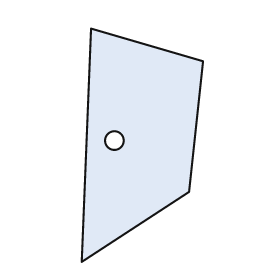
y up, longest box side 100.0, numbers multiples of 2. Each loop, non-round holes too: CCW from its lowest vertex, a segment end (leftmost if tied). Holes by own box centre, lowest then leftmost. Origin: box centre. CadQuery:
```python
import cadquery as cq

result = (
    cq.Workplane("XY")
    .moveTo(-26.0, -50.0)
    .lineTo(20.0, -20.0)
    .lineTo(26.0, 36.0)
    .lineTo(-22.0, 50.0)
    .close()
    .moveTo(-12.0, 2.0)
    .circle(4.0)
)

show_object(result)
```